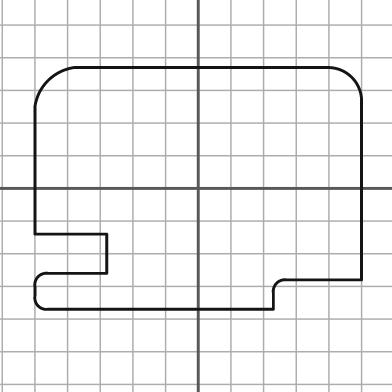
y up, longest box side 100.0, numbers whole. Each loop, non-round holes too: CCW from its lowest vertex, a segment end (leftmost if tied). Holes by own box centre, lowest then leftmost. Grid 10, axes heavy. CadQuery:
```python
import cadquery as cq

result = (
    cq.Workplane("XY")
    .moveTo(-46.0, -37.0)
    .lineTo(23.0, -37.0)
    .lineTo(23.0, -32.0)
    .threePointArc((24.0, -29.0), (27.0, -28.0))
    .lineTo(50.0, -28.0)
    .lineTo(50.0, 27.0)
    .threePointArc((47.0, 34.0), (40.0, 37.0))
    .lineTo(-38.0, 37.0)
    .threePointArc((-46.0, 33.0), (-50.0, 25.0))
    .lineTo(-50.0, -14.0)
    .lineTo(-28.0, -14.0)
    .lineTo(-28.0, -26.0)
    .lineTo(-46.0, -26.0)
    .threePointArc((-49.0, -27.0), (-50.0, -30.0))
    .lineTo(-50.0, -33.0)
    .threePointArc((-49.0, -36.0), (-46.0, -37.0))
    .close()
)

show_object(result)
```